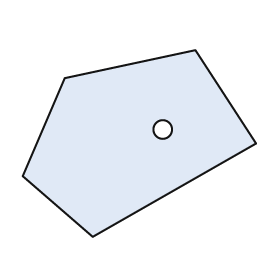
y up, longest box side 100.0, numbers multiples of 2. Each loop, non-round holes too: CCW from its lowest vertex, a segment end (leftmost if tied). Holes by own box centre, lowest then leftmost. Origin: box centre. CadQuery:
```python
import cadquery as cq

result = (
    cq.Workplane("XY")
    .moveTo(-20.0, -40.0)
    .lineTo(50.0, 0.0)
    .lineTo(24.0, 40.0)
    .lineTo(-32.0, 28.0)
    .lineTo(-50.0, -14.0)
    .close()
    .moveTo(10.0, 6.0)
    .circle(4.0)
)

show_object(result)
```